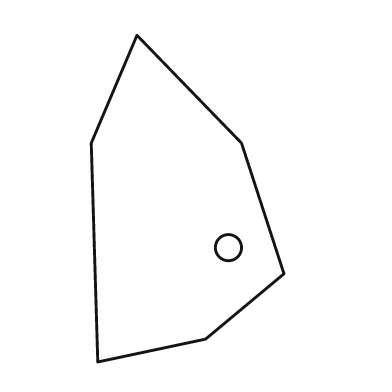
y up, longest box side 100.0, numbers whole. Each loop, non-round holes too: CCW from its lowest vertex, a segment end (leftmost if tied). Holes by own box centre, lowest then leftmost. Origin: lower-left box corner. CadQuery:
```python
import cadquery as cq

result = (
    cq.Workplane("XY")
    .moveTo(2.0, 0.0)
    .lineTo(35.0, 7.0)
    .lineTo(59.0, 27.0)
    .lineTo(46.0, 67.0)
    .lineTo(14.0, 100.0)
    .lineTo(0.0, 67.0)
    .close()
    .moveTo(42.0, 35.0)
    .circle(4.0)
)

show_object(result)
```